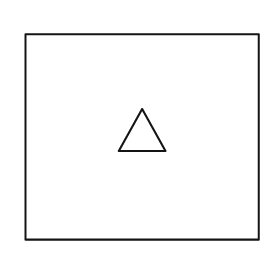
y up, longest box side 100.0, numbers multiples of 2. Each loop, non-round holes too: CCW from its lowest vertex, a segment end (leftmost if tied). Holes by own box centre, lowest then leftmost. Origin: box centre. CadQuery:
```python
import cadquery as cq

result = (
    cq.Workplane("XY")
    .moveTo(-50.0, -44.0)
    .lineTo(50.0, -44.0)
    .lineTo(50.0, 44.0)
    .lineTo(-50.0, 44.0)
    .close()
    .moveTo(-10.0, -6.0)
    .lineTo(10.0, -6.0)
    .lineTo(0.0, 12.0)
    .close()
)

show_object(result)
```